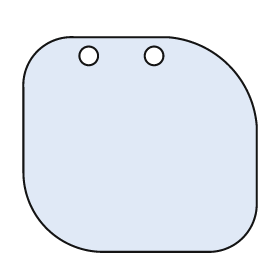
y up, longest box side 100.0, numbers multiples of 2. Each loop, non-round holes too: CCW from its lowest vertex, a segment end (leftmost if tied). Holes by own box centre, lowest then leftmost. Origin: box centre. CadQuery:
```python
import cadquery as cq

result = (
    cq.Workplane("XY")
    .moveTo(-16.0, -46.0)
    .lineTo(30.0, -46.0)
    .threePointArc((44.0, -40.0), (50.0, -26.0))
    .lineTo(50.0, 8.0)
    .threePointArc((38.0, 34.0), (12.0, 46.0))
    .lineTo(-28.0, 46.0)
    .threePointArc((-44.0, 40.0), (-50.0, 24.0))
    .lineTo(-50.0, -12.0)
    .threePointArc((-40.0, -36.0), (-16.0, -46.0))
    .close()
    .moveTo(-22.0, 38.0)
    .circle(4.0)
    .moveTo(6.0, 38.0)
    .circle(4.0)
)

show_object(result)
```